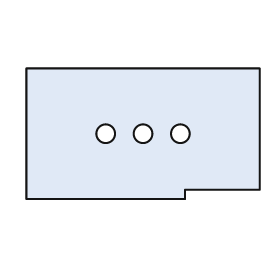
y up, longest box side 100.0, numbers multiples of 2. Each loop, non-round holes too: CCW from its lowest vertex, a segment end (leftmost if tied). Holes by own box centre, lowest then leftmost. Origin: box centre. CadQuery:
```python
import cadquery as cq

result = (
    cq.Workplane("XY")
    .moveTo(-50.0, -28.0)
    .lineTo(18.0, -28.0)
    .lineTo(18.0, -24.0)
    .lineTo(50.0, -24.0)
    .lineTo(50.0, 28.0)
    .lineTo(-50.0, 28.0)
    .close()
    .moveTo(-16.0, 0.0)
    .circle(4.0)
    .moveTo(0.0, 0.0)
    .circle(4.0)
    .moveTo(16.0, 0.0)
    .circle(4.0)
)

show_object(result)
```